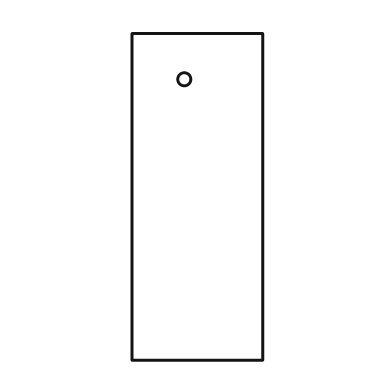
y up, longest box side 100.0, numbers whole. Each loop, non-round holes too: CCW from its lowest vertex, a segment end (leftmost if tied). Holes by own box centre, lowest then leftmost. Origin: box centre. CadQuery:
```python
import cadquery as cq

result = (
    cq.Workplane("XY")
    .moveTo(-20.0, -50.0)
    .lineTo(20.0, -50.0)
    .lineTo(20.0, 50.0)
    .lineTo(-20.0, 50.0)
    .close()
    .moveTo(-4.0, 36.0)
    .circle(2.0)
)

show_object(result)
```